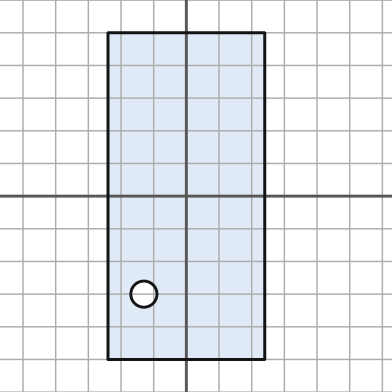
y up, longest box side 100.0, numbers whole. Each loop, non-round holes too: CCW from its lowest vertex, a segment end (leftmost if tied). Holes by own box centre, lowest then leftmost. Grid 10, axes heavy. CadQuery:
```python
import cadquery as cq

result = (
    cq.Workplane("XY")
    .moveTo(-24.0, -50.0)
    .lineTo(24.0, -50.0)
    .lineTo(24.0, 50.0)
    .lineTo(-24.0, 50.0)
    .close()
    .moveTo(-13.0, -30.0)
    .circle(4.0)
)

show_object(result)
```